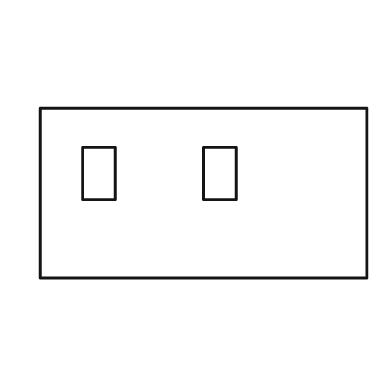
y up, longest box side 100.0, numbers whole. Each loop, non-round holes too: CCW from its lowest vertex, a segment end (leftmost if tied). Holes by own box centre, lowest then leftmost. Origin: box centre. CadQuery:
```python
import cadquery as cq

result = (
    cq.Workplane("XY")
    .moveTo(-50.0, -26.0)
    .lineTo(50.0, -26.0)
    .lineTo(50.0, 26.0)
    .lineTo(-50.0, 26.0)
    .close()
    .moveTo(-37.0, -2.0)
    .lineTo(-27.0, -2.0)
    .lineTo(-27.0, 14.0)
    .lineTo(-37.0, 14.0)
    .close()
    .moveTo(0.0, -2.0)
    .lineTo(10.0, -2.0)
    .lineTo(10.0, 14.0)
    .lineTo(0.0, 14.0)
    .close()
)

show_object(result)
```